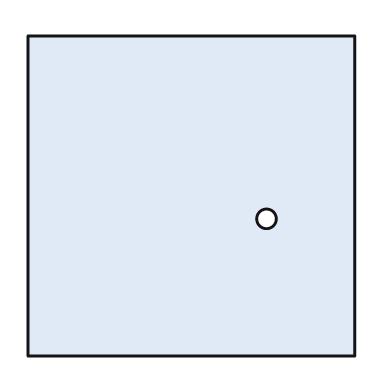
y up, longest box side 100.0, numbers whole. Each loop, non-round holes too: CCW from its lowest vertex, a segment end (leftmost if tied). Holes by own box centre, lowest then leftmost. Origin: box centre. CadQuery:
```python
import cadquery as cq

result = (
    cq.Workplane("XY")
    .moveTo(-50.0, -49.0)
    .lineTo(50.0, -49.0)
    .lineTo(50.0, 49.0)
    .lineTo(-50.0, 49.0)
    .close()
    .moveTo(23.0, -7.0)
    .circle(3.0)
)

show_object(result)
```